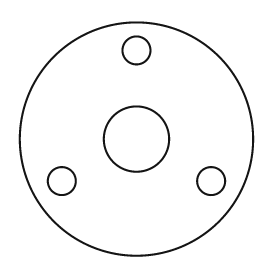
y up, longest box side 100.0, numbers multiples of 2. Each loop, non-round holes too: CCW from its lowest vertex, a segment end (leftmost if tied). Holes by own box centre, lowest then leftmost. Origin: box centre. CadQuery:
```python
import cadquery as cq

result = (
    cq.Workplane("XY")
    .moveTo(0.0, 0.0)
    .circle(50.0)
    .moveTo(-32.0, -18.0)
    .circle(6.0)
    .moveTo(32.0, -18.0)
    .circle(6.0)
    .moveTo(0.0, 0.0)
    .circle(14.0)
    .moveTo(0.0, 38.0)
    .circle(6.0)
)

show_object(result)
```